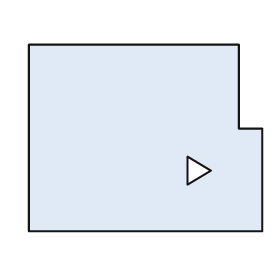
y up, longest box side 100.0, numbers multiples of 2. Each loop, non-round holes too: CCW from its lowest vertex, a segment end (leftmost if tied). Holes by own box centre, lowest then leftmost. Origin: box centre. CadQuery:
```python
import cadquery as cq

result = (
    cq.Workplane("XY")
    .moveTo(-50.0, -40.0)
    .lineTo(50.0, -40.0)
    .lineTo(50.0, 4.0)
    .lineTo(40.0, 4.0)
    .lineTo(40.0, 40.0)
    .lineTo(-50.0, 40.0)
    .close()
    .moveTo(18.0, -20.0)
    .lineTo(28.0, -14.0)
    .lineTo(18.0, -8.0)
    .close()
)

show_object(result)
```